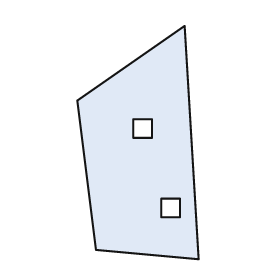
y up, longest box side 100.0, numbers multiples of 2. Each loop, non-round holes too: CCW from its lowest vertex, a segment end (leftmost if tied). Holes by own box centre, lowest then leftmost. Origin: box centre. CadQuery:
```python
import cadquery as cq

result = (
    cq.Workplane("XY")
    .moveTo(26.0, -50.0)
    .lineTo(20.0, 50.0)
    .lineTo(-26.0, 18.0)
    .lineTo(-18.0, -46.0)
    .close()
    .moveTo(10.0, -32.0)
    .lineTo(18.0, -32.0)
    .lineTo(18.0, -24.0)
    .lineTo(10.0, -24.0)
    .close()
    .moveTo(-2.0, 2.0)
    .lineTo(6.0, 2.0)
    .lineTo(6.0, 10.0)
    .lineTo(-2.0, 10.0)
    .close()
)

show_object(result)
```